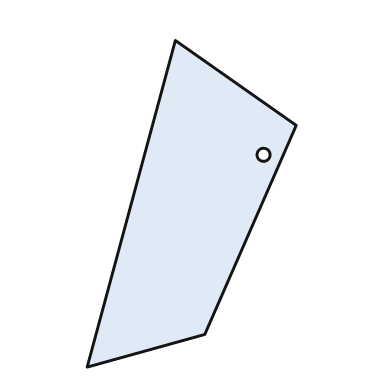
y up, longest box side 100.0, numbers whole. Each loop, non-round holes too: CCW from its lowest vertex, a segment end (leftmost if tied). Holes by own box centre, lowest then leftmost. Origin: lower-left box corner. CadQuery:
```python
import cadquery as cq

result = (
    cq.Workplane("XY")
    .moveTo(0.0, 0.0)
    .lineTo(36.0, 10.0)
    .lineTo(64.0, 74.0)
    .lineTo(27.0, 100.0)
    .close()
    .moveTo(54.0, 65.0)
    .circle(2.0)
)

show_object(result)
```